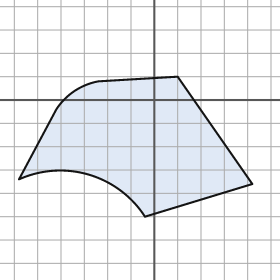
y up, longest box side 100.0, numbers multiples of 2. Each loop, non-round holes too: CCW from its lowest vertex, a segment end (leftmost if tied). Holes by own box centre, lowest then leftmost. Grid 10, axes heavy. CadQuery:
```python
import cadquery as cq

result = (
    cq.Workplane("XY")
    .moveTo(-4.0, -50.0)
    .lineTo(42.0, -36.0)
    .lineTo(10.0, 10.0)
    .lineTo(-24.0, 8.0)
    .threePointArc((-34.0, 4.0), (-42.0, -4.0))
    .lineTo(-58.0, -34.0)
    .threePointArc((-28.0, -32.0), (-4.0, -50.0))
    .close()
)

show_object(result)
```